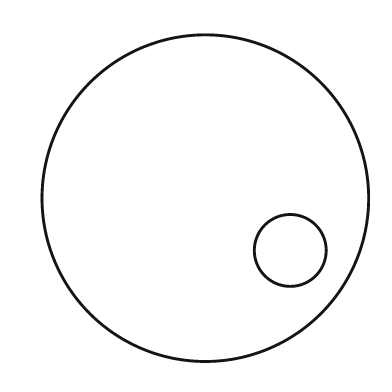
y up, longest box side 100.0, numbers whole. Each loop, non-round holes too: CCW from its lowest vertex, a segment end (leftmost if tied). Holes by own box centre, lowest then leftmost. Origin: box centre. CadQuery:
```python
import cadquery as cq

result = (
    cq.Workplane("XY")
    .moveTo(0.0, 0.0)
    .circle(50.0)
    .moveTo(26.0, -16.0)
    .circle(11.0)
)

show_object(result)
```